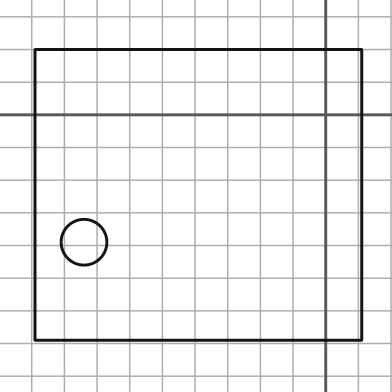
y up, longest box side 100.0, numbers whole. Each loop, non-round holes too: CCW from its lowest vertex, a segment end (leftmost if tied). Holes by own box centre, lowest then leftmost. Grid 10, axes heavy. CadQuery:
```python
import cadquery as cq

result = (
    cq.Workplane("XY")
    .moveTo(-89.0, -69.0)
    .lineTo(11.0, -69.0)
    .lineTo(11.0, 20.0)
    .lineTo(-89.0, 20.0)
    .close()
    .moveTo(-74.0, -39.0)
    .circle(7.0)
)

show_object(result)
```